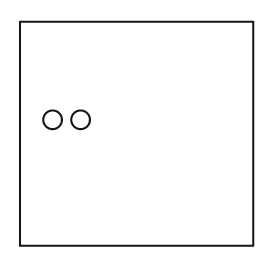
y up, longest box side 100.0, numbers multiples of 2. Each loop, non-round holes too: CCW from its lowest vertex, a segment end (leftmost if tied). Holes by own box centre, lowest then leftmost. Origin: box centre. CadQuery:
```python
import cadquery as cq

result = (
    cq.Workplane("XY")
    .moveTo(-50.0, -48.0)
    .lineTo(50.0, -48.0)
    .lineTo(50.0, 48.0)
    .lineTo(-50.0, 48.0)
    .close()
    .moveTo(-36.0, 6.0)
    .circle(4.0)
    .moveTo(-24.0, 6.0)
    .circle(4.0)
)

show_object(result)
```